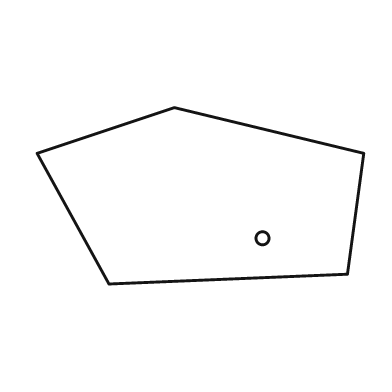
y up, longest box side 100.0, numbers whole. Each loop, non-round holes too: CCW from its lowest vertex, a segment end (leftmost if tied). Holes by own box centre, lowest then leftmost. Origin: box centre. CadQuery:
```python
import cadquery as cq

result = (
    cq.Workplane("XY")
    .moveTo(-28.0, -27.0)
    .lineTo(45.0, -24.0)
    .lineTo(50.0, 13.0)
    .lineTo(-8.0, 27.0)
    .lineTo(-50.0, 13.0)
    .close()
    .moveTo(19.0, -13.0)
    .circle(2.0)
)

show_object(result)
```